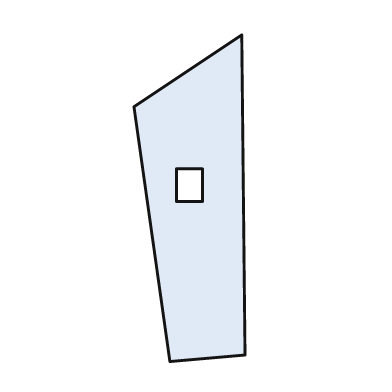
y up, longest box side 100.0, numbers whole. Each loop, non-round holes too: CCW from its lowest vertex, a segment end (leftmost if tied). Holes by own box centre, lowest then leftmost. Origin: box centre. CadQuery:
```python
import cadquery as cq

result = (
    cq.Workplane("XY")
    .moveTo(-6.0, -50.0)
    .lineTo(17.0, -48.0)
    .lineTo(16.0, 50.0)
    .lineTo(-17.0, 28.0)
    .close()
    .moveTo(-4.0, -1.0)
    .lineTo(4.0, -1.0)
    .lineTo(4.0, 9.0)
    .lineTo(-4.0, 9.0)
    .close()
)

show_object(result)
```